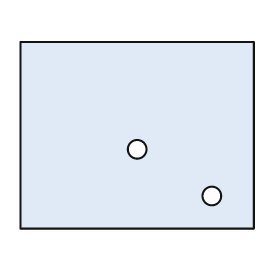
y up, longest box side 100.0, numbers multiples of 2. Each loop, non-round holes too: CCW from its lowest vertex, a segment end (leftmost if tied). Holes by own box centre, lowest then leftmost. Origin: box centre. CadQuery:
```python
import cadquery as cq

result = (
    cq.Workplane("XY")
    .moveTo(-50.0, -40.0)
    .lineTo(50.0, -40.0)
    .lineTo(50.0, 40.0)
    .lineTo(-50.0, 40.0)
    .close()
    .moveTo(32.0, -26.0)
    .circle(4.0)
    .moveTo(0.0, -6.0)
    .circle(4.0)
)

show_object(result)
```